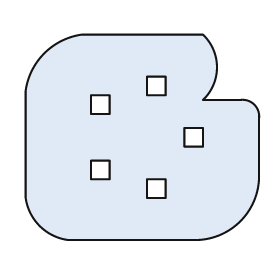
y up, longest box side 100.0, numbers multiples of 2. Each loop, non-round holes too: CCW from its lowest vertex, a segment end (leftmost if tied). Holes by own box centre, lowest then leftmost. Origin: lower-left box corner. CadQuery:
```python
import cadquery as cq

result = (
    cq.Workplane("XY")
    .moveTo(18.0, 0.0)
    .lineTo(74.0, 0.0)
    .threePointArc((92.0, 8.0), (100.0, 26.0))
    .lineTo(100.0, 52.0)
    .threePointArc((98.0, 58.0), (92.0, 60.0))
    .lineTo(76.0, 60.0)
    .threePointArc((82.0, 74.0), (76.0, 88.0))
    .lineTo(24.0, 88.0)
    .threePointArc((8.0, 80.0), (0.0, 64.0))
    .lineTo(0.0, 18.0)
    .threePointArc((6.0, 6.0), (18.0, 0.0))
    .close()
    .moveTo(52.0, 18.0)
    .lineTo(60.0, 18.0)
    .lineTo(60.0, 26.0)
    .lineTo(52.0, 26.0)
    .close()
    .moveTo(28.0, 26.0)
    .lineTo(36.0, 26.0)
    .lineTo(36.0, 34.0)
    .lineTo(28.0, 34.0)
    .close()
    .moveTo(68.0, 40.0)
    .lineTo(76.0, 40.0)
    .lineTo(76.0, 48.0)
    .lineTo(68.0, 48.0)
    .close()
    .moveTo(28.0, 54.0)
    .lineTo(36.0, 54.0)
    .lineTo(36.0, 62.0)
    .lineTo(28.0, 62.0)
    .close()
    .moveTo(52.0, 62.0)
    .lineTo(60.0, 62.0)
    .lineTo(60.0, 70.0)
    .lineTo(52.0, 70.0)
    .close()
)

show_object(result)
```